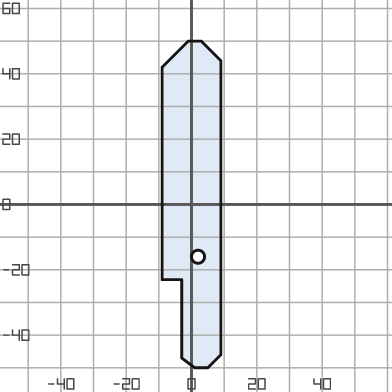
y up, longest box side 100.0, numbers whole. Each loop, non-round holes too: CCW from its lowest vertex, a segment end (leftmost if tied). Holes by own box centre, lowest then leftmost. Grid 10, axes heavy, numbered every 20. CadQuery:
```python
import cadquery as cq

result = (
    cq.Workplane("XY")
    .moveTo(1.0, -50.0)
    .lineTo(5.0, -50.0)
    .lineTo(9.0, -46.0)
    .lineTo(9.0, 44.0)
    .lineTo(3.0, 50.0)
    .lineTo(-1.0, 50.0)
    .lineTo(-9.0, 42.0)
    .lineTo(-9.0, -23.0)
    .lineTo(-3.0, -23.0)
    .lineTo(-3.0, -47.0)
    .close()
    .moveTo(2.0, -16.0)
    .circle(2.0)
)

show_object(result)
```